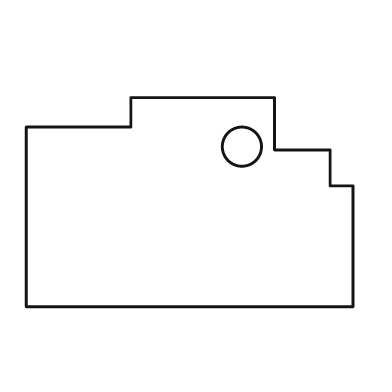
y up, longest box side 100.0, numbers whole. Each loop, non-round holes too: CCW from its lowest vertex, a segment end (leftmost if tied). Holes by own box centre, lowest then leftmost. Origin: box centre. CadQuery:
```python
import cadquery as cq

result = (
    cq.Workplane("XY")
    .moveTo(-50.0, -32.0)
    .lineTo(50.0, -32.0)
    .lineTo(50.0, 5.0)
    .lineTo(43.0, 5.0)
    .lineTo(43.0, 16.0)
    .lineTo(26.0, 16.0)
    .lineTo(26.0, 32.0)
    .lineTo(-18.0, 32.0)
    .lineTo(-18.0, 23.0)
    .lineTo(-50.0, 23.0)
    .close()
    .moveTo(16.0, 17.0)
    .circle(6.0)
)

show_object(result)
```